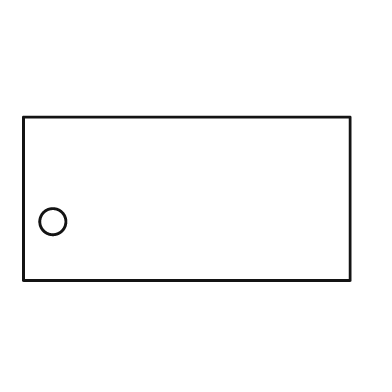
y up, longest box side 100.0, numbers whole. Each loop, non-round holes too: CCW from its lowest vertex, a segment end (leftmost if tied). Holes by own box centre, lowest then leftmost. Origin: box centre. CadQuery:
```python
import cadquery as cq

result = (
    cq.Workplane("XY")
    .moveTo(-50.0, -25.0)
    .lineTo(50.0, -25.0)
    .lineTo(50.0, 25.0)
    .lineTo(-50.0, 25.0)
    .close()
    .moveTo(-41.0, -7.0)
    .circle(4.0)
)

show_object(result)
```